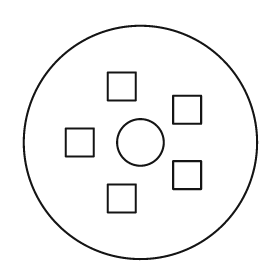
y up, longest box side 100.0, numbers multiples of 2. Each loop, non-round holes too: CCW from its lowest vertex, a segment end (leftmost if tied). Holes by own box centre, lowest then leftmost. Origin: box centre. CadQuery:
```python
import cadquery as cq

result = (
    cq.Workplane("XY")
    .moveTo(0.0, 0.0)
    .circle(50.0)
    .moveTo(-14.0, -30.0)
    .lineTo(-2.0, -30.0)
    .lineTo(-2.0, -18.0)
    .lineTo(-14.0, -18.0)
    .close()
    .moveTo(14.0, -20.0)
    .lineTo(26.0, -20.0)
    .lineTo(26.0, -8.0)
    .lineTo(14.0, -8.0)
    .close()
    .moveTo(-32.0, -6.0)
    .lineTo(-20.0, -6.0)
    .lineTo(-20.0, 6.0)
    .lineTo(-32.0, 6.0)
    .close()
    .moveTo(0.0, 0.0)
    .circle(10.0)
    .moveTo(14.0, 8.0)
    .lineTo(26.0, 8.0)
    .lineTo(26.0, 20.0)
    .lineTo(14.0, 20.0)
    .close()
    .moveTo(-14.0, 18.0)
    .lineTo(-2.0, 18.0)
    .lineTo(-2.0, 30.0)
    .lineTo(-14.0, 30.0)
    .close()
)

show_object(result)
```